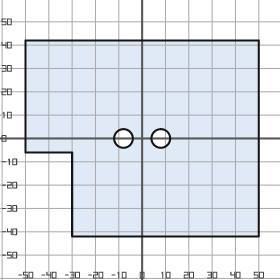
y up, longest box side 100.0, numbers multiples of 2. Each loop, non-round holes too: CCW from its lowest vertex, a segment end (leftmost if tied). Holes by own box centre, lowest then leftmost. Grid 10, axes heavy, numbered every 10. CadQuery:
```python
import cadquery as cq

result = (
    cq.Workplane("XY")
    .moveTo(-30.0, -42.0)
    .lineTo(50.0, -42.0)
    .lineTo(50.0, 42.0)
    .lineTo(-50.0, 42.0)
    .lineTo(-50.0, -6.0)
    .lineTo(-30.0, -6.0)
    .close()
    .moveTo(-8.0, 0.0)
    .circle(4.0)
    .moveTo(8.0, 0.0)
    .circle(4.0)
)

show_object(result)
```